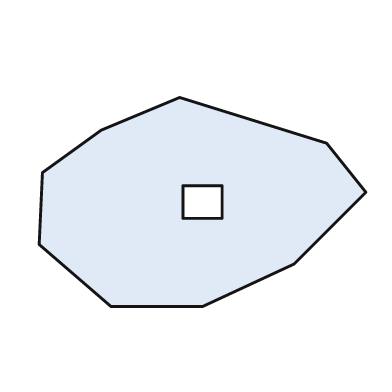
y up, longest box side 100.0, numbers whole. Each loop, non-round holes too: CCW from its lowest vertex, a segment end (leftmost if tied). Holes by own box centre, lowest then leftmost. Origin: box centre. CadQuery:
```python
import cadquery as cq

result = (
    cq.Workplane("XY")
    .moveTo(-28.0, -32.0)
    .lineTo(0.0, -32.0)
    .lineTo(28.0, -19.0)
    .lineTo(50.0, 3.0)
    .lineTo(38.0, 18.0)
    .lineTo(-7.0, 32.0)
    .lineTo(-31.0, 22.0)
    .lineTo(-49.0, 9.0)
    .lineTo(-50.0, -13.0)
    .close()
    .moveTo(-6.0, -5.0)
    .lineTo(6.0, -5.0)
    .lineTo(6.0, 5.0)
    .lineTo(-6.0, 5.0)
    .close()
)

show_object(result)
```